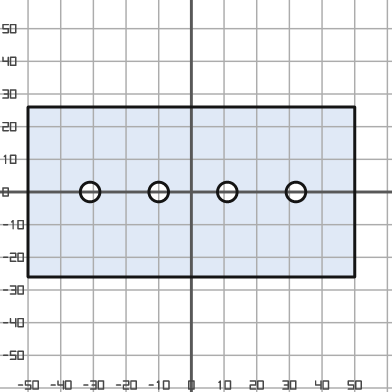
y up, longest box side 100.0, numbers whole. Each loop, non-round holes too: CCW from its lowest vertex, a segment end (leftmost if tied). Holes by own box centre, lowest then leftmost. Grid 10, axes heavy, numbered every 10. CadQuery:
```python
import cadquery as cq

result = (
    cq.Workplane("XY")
    .moveTo(-50.0, -26.0)
    .lineTo(50.0, -26.0)
    .lineTo(50.0, 26.0)
    .lineTo(-50.0, 26.0)
    .close()
    .moveTo(-31.0, 0.0)
    .circle(3.0)
    .moveTo(-10.0, 0.0)
    .circle(3.0)
    .moveTo(11.0, 0.0)
    .circle(3.0)
    .moveTo(32.0, 0.0)
    .circle(3.0)
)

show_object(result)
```